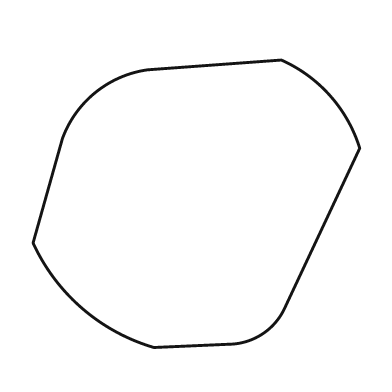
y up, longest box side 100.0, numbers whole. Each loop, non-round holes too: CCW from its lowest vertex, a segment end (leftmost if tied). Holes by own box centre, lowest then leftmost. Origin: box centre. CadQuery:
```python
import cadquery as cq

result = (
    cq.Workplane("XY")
    .moveTo(-13.0, -44.0)
    .lineTo(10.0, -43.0)
    .threePointArc((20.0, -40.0), (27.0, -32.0))
    .lineTo(50.0, 17.0)
    .threePointArc((41.0, 33.0), (26.0, 44.0))
    .lineTo(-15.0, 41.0)
    .threePointArc((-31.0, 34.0), (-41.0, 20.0))
    .lineTo(-50.0, -12.0)
    .threePointArc((-35.0, -32.0), (-13.0, -44.0))
    .close()
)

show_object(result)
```